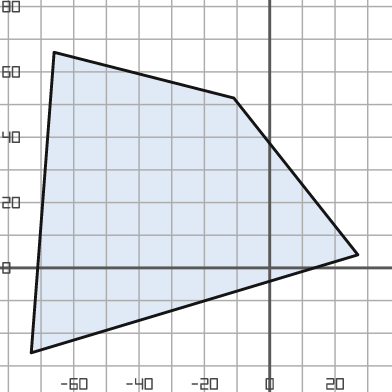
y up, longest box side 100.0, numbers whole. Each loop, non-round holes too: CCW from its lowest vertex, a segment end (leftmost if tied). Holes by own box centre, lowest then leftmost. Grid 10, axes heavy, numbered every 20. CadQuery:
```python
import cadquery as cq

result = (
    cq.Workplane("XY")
    .moveTo(-73.0, -26.0)
    .lineTo(27.0, 4.0)
    .lineTo(-11.0, 52.0)
    .lineTo(-66.0, 66.0)
    .close()
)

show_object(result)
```